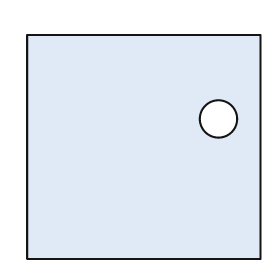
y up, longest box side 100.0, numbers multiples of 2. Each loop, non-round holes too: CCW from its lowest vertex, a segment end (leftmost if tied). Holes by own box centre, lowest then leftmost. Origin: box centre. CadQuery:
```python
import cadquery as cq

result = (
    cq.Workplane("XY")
    .moveTo(-50.0, -48.0)
    .lineTo(50.0, -48.0)
    .lineTo(50.0, 48.0)
    .lineTo(-50.0, 48.0)
    .close()
    .moveTo(32.0, 12.0)
    .circle(8.0)
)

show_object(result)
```